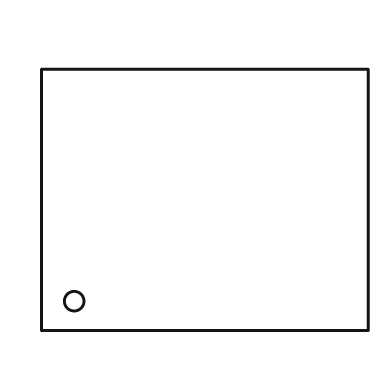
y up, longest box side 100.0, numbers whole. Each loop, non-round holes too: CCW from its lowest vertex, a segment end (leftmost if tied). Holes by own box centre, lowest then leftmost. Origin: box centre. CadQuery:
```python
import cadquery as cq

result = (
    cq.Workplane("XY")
    .moveTo(-50.0, -40.0)
    .lineTo(50.0, -40.0)
    .lineTo(50.0, 40.0)
    .lineTo(-50.0, 40.0)
    .close()
    .moveTo(-40.0, -31.0)
    .circle(3.0)
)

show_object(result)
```